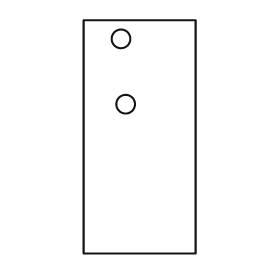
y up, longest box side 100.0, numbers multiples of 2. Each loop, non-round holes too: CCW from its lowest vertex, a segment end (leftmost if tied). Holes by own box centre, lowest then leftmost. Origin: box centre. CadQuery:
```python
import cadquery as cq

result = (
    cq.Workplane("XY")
    .moveTo(-24.0, -50.0)
    .lineTo(24.0, -50.0)
    .lineTo(24.0, 50.0)
    .lineTo(-24.0, 50.0)
    .close()
    .moveTo(-6.0, 14.0)
    .circle(4.0)
    .moveTo(-8.0, 42.0)
    .circle(4.0)
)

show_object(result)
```